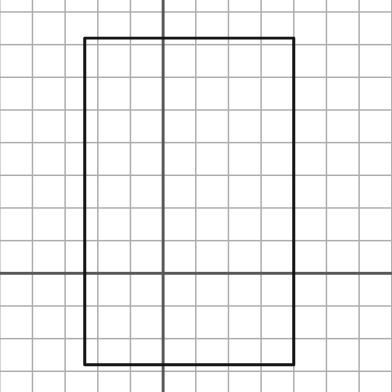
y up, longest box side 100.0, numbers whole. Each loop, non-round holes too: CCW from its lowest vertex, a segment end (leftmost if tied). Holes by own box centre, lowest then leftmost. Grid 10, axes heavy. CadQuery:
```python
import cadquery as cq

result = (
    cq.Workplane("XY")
    .moveTo(-24.0, -28.0)
    .lineTo(40.0, -28.0)
    .lineTo(40.0, 72.0)
    .lineTo(-24.0, 72.0)
    .close()
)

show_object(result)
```